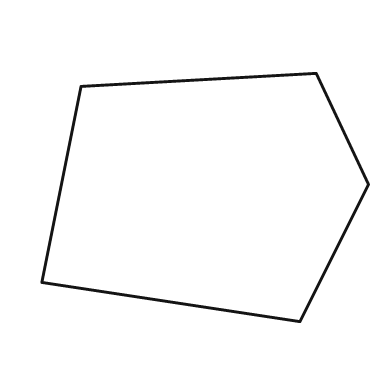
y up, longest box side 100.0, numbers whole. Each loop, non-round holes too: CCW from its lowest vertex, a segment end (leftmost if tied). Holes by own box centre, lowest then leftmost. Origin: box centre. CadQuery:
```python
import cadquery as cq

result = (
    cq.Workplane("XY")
    .moveTo(29.0, -38.0)
    .lineTo(50.0, 4.0)
    .lineTo(34.0, 38.0)
    .lineTo(-38.0, 34.0)
    .lineTo(-50.0, -26.0)
    .close()
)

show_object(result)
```